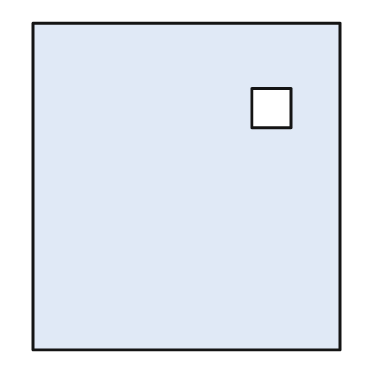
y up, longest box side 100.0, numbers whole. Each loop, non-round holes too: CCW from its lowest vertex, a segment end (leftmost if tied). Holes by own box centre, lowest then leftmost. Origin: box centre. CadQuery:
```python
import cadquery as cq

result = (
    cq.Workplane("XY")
    .moveTo(-47.0, -50.0)
    .lineTo(47.0, -50.0)
    .lineTo(47.0, 50.0)
    .lineTo(-47.0, 50.0)
    .close()
    .moveTo(20.0, 18.0)
    .lineTo(32.0, 18.0)
    .lineTo(32.0, 30.0)
    .lineTo(20.0, 30.0)
    .close()
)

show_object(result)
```